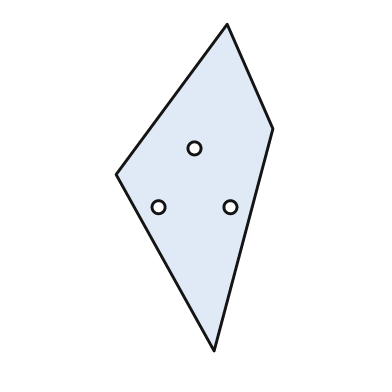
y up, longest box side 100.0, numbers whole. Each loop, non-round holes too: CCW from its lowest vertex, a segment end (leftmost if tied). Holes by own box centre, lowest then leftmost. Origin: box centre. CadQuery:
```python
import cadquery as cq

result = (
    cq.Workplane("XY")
    .moveTo(6.0, -50.0)
    .lineTo(24.0, 18.0)
    .lineTo(10.0, 50.0)
    .lineTo(-24.0, 4.0)
    .close()
    .moveTo(-11.0, -6.0)
    .circle(2.0)
    .moveTo(11.0, -6.0)
    .circle(2.0)
    .moveTo(0.0, 12.0)
    .circle(2.0)
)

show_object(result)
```